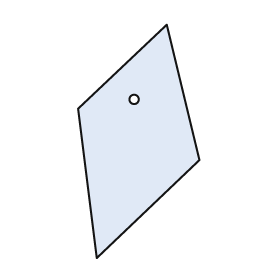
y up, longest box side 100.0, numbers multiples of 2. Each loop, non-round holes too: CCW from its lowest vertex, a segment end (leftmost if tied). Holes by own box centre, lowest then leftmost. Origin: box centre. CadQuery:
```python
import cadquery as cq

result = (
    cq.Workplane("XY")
    .moveTo(-18.0, -50.0)
    .lineTo(26.0, -8.0)
    .lineTo(12.0, 50.0)
    .lineTo(-26.0, 14.0)
    .close()
    .moveTo(-2.0, 18.0)
    .circle(2.0)
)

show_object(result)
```